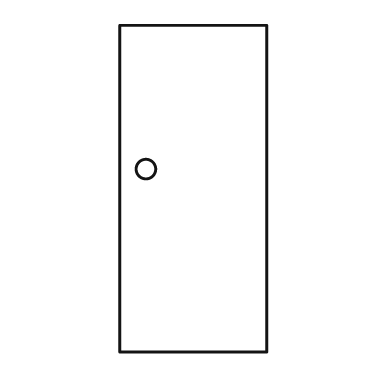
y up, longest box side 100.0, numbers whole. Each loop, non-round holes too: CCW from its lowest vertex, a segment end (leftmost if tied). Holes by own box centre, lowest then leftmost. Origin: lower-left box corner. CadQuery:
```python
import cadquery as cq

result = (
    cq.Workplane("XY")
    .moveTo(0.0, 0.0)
    .lineTo(45.0, 0.0)
    .lineTo(45.0, 100.0)
    .lineTo(0.0, 100.0)
    .close()
    .moveTo(8.0, 56.0)
    .circle(3.0)
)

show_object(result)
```